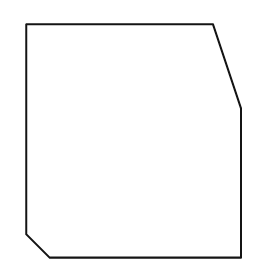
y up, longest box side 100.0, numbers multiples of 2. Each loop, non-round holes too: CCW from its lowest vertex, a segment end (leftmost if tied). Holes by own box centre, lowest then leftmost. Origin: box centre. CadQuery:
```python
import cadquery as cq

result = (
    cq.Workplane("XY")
    .moveTo(-36.0, -50.0)
    .lineTo(46.0, -50.0)
    .lineTo(46.0, 14.0)
    .lineTo(34.0, 50.0)
    .lineTo(-46.0, 50.0)
    .lineTo(-46.0, -40.0)
    .close()
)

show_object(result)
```